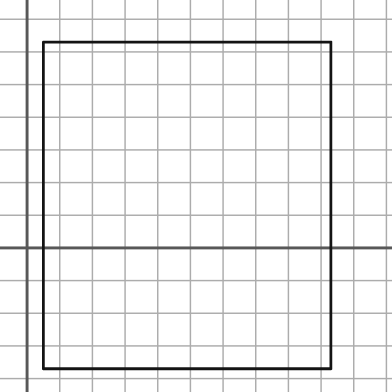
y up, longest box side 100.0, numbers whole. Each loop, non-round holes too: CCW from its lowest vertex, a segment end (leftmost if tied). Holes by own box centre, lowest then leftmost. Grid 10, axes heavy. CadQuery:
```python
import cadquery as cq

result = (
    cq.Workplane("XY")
    .moveTo(5.0, -37.0)
    .lineTo(93.0, -37.0)
    .lineTo(93.0, 63.0)
    .lineTo(5.0, 63.0)
    .close()
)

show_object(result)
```